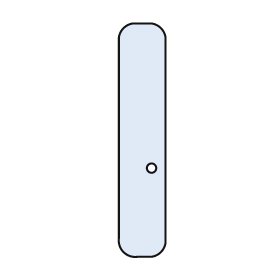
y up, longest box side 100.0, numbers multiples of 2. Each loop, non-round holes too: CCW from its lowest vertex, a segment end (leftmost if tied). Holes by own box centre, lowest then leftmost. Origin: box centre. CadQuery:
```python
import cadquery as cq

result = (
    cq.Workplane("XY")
    .moveTo(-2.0, -50.0)
    .lineTo(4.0, -50.0)
    .threePointArc((8.0, -48.0), (10.0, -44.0))
    .lineTo(10.0, 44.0)
    .threePointArc((8.0, 48.0), (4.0, 50.0))
    .lineTo(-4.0, 50.0)
    .threePointArc((-8.0, 48.0), (-10.0, 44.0))
    .lineTo(-10.0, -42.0)
    .threePointArc((-8.0, -48.0), (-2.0, -50.0))
    .close()
    .moveTo(4.0, -12.0)
    .circle(2.0)
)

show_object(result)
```